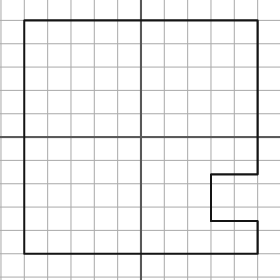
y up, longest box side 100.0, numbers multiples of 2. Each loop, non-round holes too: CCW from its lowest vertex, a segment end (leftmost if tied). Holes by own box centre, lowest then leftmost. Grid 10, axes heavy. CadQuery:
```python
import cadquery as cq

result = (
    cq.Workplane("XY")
    .moveTo(-50.0, -50.0)
    .lineTo(50.0, -50.0)
    .lineTo(50.0, -36.0)
    .lineTo(30.0, -36.0)
    .lineTo(30.0, -16.0)
    .lineTo(50.0, -16.0)
    .lineTo(50.0, 50.0)
    .lineTo(-50.0, 50.0)
    .close()
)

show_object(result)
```